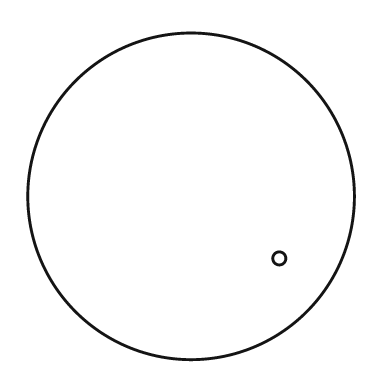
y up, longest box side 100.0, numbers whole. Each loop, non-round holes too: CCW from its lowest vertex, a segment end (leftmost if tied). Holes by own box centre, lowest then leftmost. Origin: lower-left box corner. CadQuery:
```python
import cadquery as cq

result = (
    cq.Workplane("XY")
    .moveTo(50.0, 50.0)
    .circle(50.0)
    .moveTo(77.0, 31.0)
    .circle(2.0)
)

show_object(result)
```